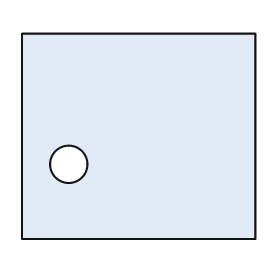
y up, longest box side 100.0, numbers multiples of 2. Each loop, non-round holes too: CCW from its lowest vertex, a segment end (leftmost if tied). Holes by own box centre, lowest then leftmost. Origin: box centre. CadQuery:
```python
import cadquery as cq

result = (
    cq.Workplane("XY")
    .moveTo(-50.0, -44.0)
    .lineTo(50.0, -44.0)
    .lineTo(50.0, 44.0)
    .lineTo(-50.0, 44.0)
    .close()
    .moveTo(-30.0, -12.0)
    .circle(8.0)
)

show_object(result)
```